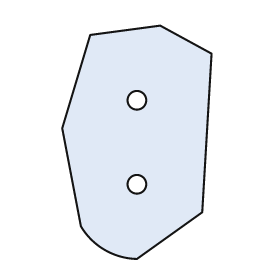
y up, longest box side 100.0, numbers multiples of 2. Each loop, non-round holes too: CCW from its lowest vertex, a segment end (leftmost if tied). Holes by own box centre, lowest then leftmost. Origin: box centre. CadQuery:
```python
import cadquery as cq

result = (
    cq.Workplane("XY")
    .moveTo(0.0, -50.0)
    .lineTo(28.0, -30.0)
    .lineTo(32.0, 38.0)
    .lineTo(10.0, 50.0)
    .lineTo(-20.0, 46.0)
    .lineTo(-32.0, 6.0)
    .lineTo(-24.0, -36.0)
    .threePointArc((-14.0, -46.0), (0.0, -50.0))
    .close()
    .moveTo(0.0, -18.0)
    .circle(4.0)
    .moveTo(0.0, 18.0)
    .circle(4.0)
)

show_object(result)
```